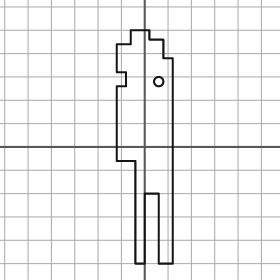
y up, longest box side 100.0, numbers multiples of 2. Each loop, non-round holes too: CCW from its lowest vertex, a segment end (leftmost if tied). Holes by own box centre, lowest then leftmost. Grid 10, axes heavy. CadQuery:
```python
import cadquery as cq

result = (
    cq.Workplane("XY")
    .moveTo(-4.0, -50.0)
    .lineTo(0.0, -50.0)
    .lineTo(0.0, -20.0)
    .lineTo(6.0, -20.0)
    .lineTo(6.0, -50.0)
    .lineTo(12.0, -50.0)
    .lineTo(12.0, 38.0)
    .lineTo(8.0, 38.0)
    .lineTo(8.0, 46.0)
    .lineTo(2.0, 46.0)
    .lineTo(2.0, 50.0)
    .lineTo(-6.0, 50.0)
    .lineTo(-6.0, 44.0)
    .lineTo(-12.0, 44.0)
    .lineTo(-12.0, 32.0)
    .lineTo(-8.0, 32.0)
    .lineTo(-8.0, 26.0)
    .lineTo(-12.0, 26.0)
    .lineTo(-12.0, -6.0)
    .lineTo(-4.0, -6.0)
    .close()
    .moveTo(6.0, 28.0)
    .circle(2.0)
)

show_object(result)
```